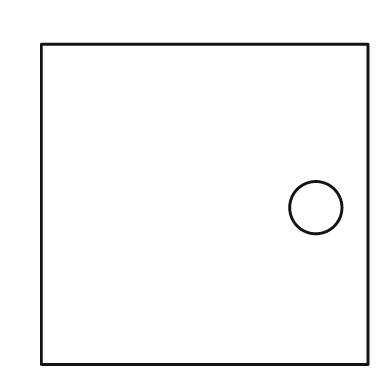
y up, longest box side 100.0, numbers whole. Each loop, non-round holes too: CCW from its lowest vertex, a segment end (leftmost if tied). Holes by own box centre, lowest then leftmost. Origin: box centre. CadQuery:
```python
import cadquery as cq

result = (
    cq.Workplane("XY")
    .moveTo(-50.0, -49.0)
    .lineTo(50.0, -49.0)
    .lineTo(50.0, 49.0)
    .lineTo(-50.0, 49.0)
    .close()
    .moveTo(34.0, -1.0)
    .circle(8.0)
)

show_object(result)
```